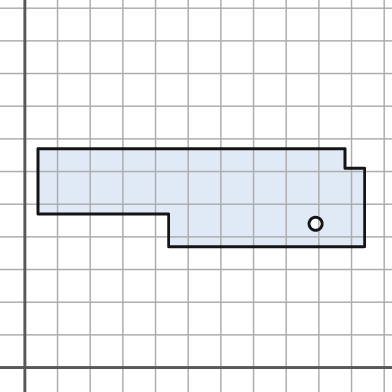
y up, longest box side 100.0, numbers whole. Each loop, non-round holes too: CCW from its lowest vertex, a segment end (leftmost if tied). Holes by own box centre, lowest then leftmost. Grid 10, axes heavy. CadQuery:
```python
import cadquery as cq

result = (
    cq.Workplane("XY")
    .moveTo(44.0, 37.0)
    .lineTo(104.0, 37.0)
    .lineTo(104.0, 61.0)
    .lineTo(98.0, 61.0)
    .lineTo(98.0, 67.0)
    .lineTo(4.0, 67.0)
    .lineTo(4.0, 47.0)
    .lineTo(44.0, 47.0)
    .close()
    .moveTo(89.0, 44.0)
    .circle(2.0)
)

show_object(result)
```